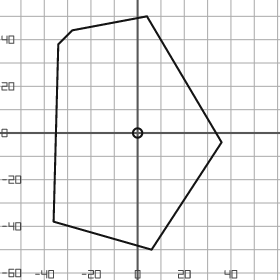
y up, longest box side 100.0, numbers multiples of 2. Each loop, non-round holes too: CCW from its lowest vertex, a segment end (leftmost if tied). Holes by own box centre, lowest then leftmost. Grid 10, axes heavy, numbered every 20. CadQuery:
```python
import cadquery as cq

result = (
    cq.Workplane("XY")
    .moveTo(6.0, -50.0)
    .lineTo(36.0, -4.0)
    .lineTo(4.0, 50.0)
    .lineTo(-28.0, 44.0)
    .lineTo(-34.0, 38.0)
    .lineTo(-36.0, -38.0)
    .close()
    .moveTo(0.0, 0.0)
    .circle(2.0)
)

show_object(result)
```